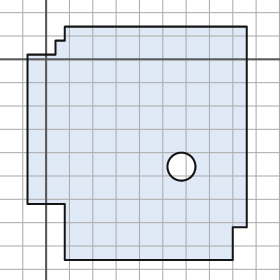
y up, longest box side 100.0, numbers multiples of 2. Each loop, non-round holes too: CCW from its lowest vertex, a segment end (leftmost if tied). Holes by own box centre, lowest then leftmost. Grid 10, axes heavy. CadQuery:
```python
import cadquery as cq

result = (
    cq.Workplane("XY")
    .moveTo(8.0, -86.0)
    .lineTo(80.0, -86.0)
    .lineTo(80.0, -72.0)
    .lineTo(86.0, -72.0)
    .lineTo(86.0, 14.0)
    .lineTo(8.0, 14.0)
    .lineTo(8.0, 8.0)
    .lineTo(4.0, 8.0)
    .lineTo(4.0, 2.0)
    .lineTo(-8.0, 2.0)
    .lineTo(-8.0, -62.0)
    .lineTo(8.0, -62.0)
    .close()
    .moveTo(58.0, -46.0)
    .circle(6.0)
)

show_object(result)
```